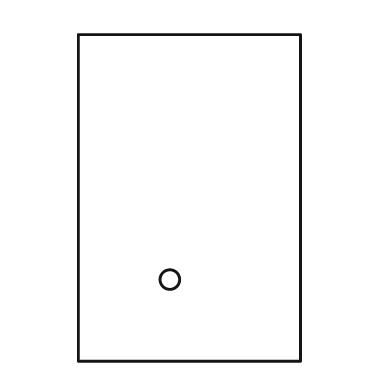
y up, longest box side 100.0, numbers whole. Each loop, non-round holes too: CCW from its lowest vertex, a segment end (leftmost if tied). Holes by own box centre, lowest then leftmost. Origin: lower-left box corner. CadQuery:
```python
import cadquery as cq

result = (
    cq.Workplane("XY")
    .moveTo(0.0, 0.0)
    .lineTo(68.0, 0.0)
    .lineTo(68.0, 100.0)
    .lineTo(0.0, 100.0)
    .close()
    .moveTo(28.0, 25.0)
    .circle(3.0)
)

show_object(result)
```